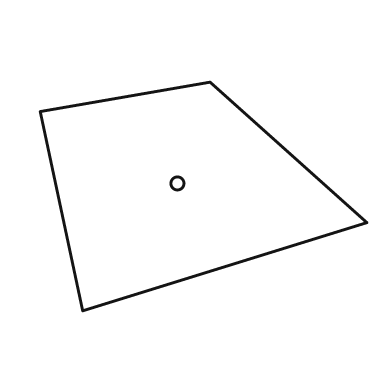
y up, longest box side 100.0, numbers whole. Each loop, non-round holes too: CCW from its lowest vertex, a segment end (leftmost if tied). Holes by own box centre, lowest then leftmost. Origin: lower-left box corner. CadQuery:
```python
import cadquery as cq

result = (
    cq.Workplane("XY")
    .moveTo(13.0, 0.0)
    .lineTo(100.0, 27.0)
    .lineTo(52.0, 70.0)
    .lineTo(0.0, 61.0)
    .close()
    .moveTo(42.0, 39.0)
    .circle(2.0)
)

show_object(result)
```